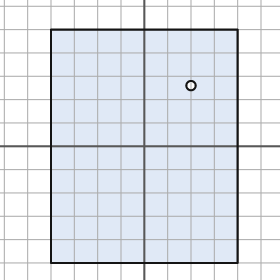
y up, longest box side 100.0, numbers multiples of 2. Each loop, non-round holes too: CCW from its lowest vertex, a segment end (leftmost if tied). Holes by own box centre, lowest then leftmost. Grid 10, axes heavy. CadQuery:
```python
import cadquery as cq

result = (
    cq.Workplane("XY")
    .moveTo(-40.0, -50.0)
    .lineTo(40.0, -50.0)
    .lineTo(40.0, 50.0)
    .lineTo(-40.0, 50.0)
    .close()
    .moveTo(20.0, 26.0)
    .circle(2.0)
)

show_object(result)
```